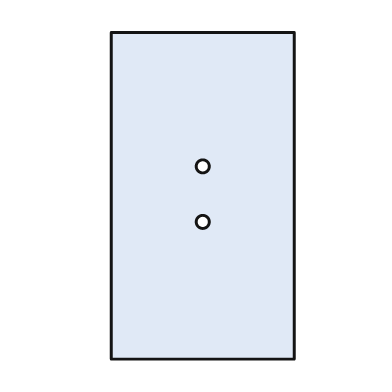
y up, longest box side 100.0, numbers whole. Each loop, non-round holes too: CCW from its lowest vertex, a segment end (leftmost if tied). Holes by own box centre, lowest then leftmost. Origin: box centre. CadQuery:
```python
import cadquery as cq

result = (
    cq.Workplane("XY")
    .moveTo(-28.0, -50.0)
    .lineTo(28.0, -50.0)
    .lineTo(28.0, 50.0)
    .lineTo(-28.0, 50.0)
    .close()
    .moveTo(0.0, -8.0)
    .circle(2.0)
    .moveTo(0.0, 9.0)
    .circle(2.0)
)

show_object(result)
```